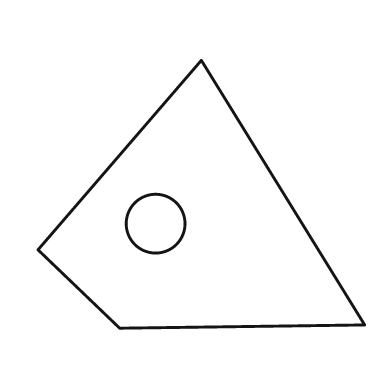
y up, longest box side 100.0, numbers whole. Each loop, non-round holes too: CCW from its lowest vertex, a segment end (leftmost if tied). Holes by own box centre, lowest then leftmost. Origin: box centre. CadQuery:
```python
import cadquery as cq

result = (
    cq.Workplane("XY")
    .moveTo(-25.0, -41.0)
    .lineTo(50.0, -40.0)
    .lineTo(0.0, 41.0)
    .lineTo(-50.0, -17.0)
    .close()
    .moveTo(-14.0, -9.0)
    .circle(9.0)
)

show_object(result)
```